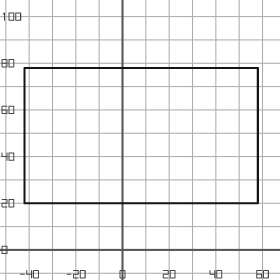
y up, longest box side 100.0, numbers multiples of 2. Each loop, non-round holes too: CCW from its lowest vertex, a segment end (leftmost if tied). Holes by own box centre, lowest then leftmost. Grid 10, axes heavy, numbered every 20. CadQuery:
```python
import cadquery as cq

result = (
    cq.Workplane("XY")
    .moveTo(-42.0, 20.0)
    .lineTo(58.0, 20.0)
    .lineTo(58.0, 78.0)
    .lineTo(-42.0, 78.0)
    .close()
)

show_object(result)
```